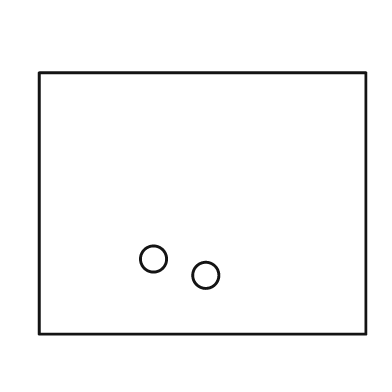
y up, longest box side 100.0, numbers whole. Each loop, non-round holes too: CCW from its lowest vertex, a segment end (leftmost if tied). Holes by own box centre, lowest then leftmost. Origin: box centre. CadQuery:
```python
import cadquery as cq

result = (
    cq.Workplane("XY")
    .moveTo(-50.0, -40.0)
    .lineTo(50.0, -40.0)
    .lineTo(50.0, 40.0)
    .lineTo(-50.0, 40.0)
    .close()
    .moveTo(1.0, -22.0)
    .circle(4.0)
    .moveTo(-15.0, -17.0)
    .circle(4.0)
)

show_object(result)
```